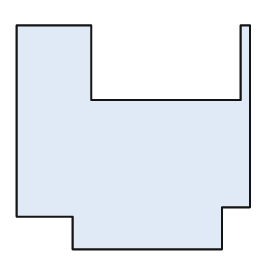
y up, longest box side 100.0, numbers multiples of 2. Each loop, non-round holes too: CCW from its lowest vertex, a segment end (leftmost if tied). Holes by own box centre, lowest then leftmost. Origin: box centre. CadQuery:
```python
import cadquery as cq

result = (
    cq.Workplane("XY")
    .moveTo(-26.0, -48.0)
    .lineTo(38.0, -48.0)
    .lineTo(38.0, -30.0)
    .lineTo(50.0, -30.0)
    .lineTo(50.0, 48.0)
    .lineTo(46.0, 48.0)
    .lineTo(46.0, 16.0)
    .lineTo(-18.0, 16.0)
    .lineTo(-18.0, 48.0)
    .lineTo(-50.0, 48.0)
    .lineTo(-50.0, -34.0)
    .lineTo(-26.0, -34.0)
    .close()
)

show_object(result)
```